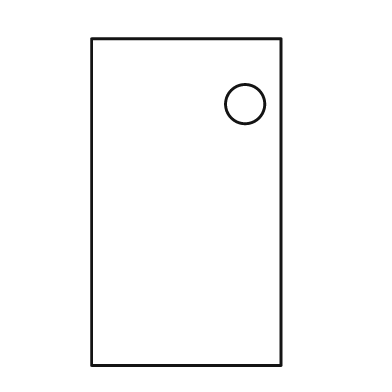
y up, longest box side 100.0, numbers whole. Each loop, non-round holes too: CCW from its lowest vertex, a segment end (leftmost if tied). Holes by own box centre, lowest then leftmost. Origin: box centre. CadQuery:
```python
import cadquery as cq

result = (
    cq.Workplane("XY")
    .moveTo(-29.0, -50.0)
    .lineTo(29.0, -50.0)
    .lineTo(29.0, 50.0)
    .lineTo(-29.0, 50.0)
    .close()
    .moveTo(18.0, 30.0)
    .circle(6.0)
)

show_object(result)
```